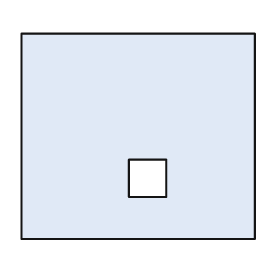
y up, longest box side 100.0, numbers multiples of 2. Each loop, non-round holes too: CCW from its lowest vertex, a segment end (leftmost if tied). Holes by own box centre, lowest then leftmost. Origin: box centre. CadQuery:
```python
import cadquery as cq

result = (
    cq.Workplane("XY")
    .moveTo(-50.0, -44.0)
    .lineTo(50.0, -44.0)
    .lineTo(50.0, 44.0)
    .lineTo(-50.0, 44.0)
    .close()
    .moveTo(-4.0, -26.0)
    .lineTo(12.0, -26.0)
    .lineTo(12.0, -10.0)
    .lineTo(-4.0, -10.0)
    .close()
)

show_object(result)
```